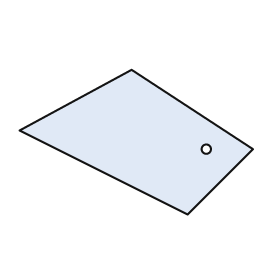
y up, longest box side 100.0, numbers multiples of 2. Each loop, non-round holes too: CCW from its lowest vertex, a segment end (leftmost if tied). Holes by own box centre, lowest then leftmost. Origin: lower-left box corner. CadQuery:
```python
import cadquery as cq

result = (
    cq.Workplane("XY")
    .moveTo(72.0, 0.0)
    .lineTo(100.0, 28.0)
    .lineTo(48.0, 62.0)
    .lineTo(0.0, 36.0)
    .close()
    .moveTo(80.0, 28.0)
    .circle(2.0)
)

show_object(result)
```